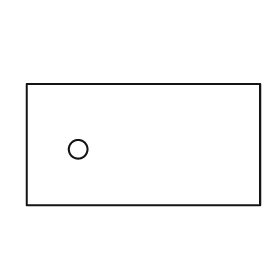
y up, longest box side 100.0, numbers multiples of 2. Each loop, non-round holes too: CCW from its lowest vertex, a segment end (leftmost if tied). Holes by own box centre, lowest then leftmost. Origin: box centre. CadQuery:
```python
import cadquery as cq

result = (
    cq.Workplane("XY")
    .moveTo(-50.0, -26.0)
    .lineTo(50.0, -26.0)
    .lineTo(50.0, 26.0)
    .lineTo(-50.0, 26.0)
    .close()
    .moveTo(-28.0, -2.0)
    .circle(4.0)
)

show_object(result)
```